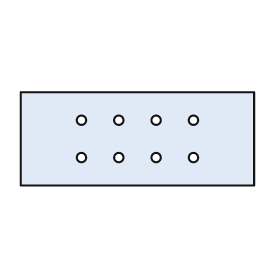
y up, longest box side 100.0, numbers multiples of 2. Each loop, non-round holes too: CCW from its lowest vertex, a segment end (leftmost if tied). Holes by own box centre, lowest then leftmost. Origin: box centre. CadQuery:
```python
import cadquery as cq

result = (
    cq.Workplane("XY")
    .moveTo(-50.0, -20.0)
    .lineTo(50.0, -20.0)
    .lineTo(50.0, 20.0)
    .lineTo(-50.0, 20.0)
    .close()
    .moveTo(-24.0, -8.0)
    .circle(2.0)
    .moveTo(-8.0, -8.0)
    .circle(2.0)
    .moveTo(8.0, -8.0)
    .circle(2.0)
    .moveTo(24.0, -8.0)
    .circle(2.0)
    .moveTo(-24.0, 8.0)
    .circle(2.0)
    .moveTo(-8.0, 8.0)
    .circle(2.0)
    .moveTo(8.0, 8.0)
    .circle(2.0)
    .moveTo(24.0, 8.0)
    .circle(2.0)
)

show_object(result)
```